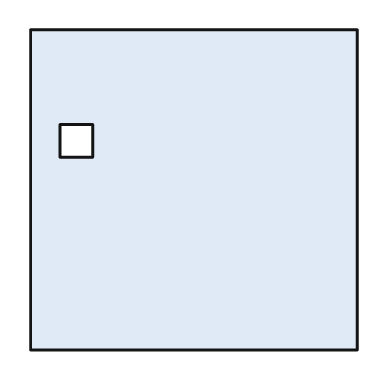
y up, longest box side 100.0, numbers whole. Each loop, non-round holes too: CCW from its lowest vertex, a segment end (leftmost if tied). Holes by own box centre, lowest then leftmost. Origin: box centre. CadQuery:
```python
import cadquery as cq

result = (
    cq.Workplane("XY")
    .moveTo(-50.0, -49.0)
    .lineTo(50.0, -49.0)
    .lineTo(50.0, 49.0)
    .lineTo(-50.0, 49.0)
    .close()
    .moveTo(-41.0, 10.0)
    .lineTo(-31.0, 10.0)
    .lineTo(-31.0, 20.0)
    .lineTo(-41.0, 20.0)
    .close()
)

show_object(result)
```